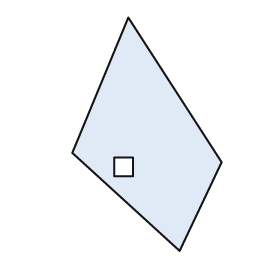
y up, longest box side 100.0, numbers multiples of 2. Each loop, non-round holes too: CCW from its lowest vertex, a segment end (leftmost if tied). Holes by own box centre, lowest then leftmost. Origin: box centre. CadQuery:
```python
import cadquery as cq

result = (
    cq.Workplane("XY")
    .moveTo(14.0, -50.0)
    .lineTo(32.0, -12.0)
    .lineTo(-8.0, 50.0)
    .lineTo(-32.0, -8.0)
    .close()
    .moveTo(-14.0, -18.0)
    .lineTo(-6.0, -18.0)
    .lineTo(-6.0, -10.0)
    .lineTo(-14.0, -10.0)
    .close()
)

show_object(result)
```